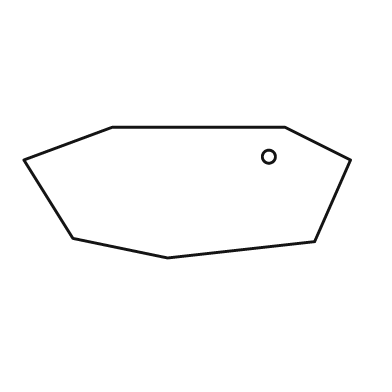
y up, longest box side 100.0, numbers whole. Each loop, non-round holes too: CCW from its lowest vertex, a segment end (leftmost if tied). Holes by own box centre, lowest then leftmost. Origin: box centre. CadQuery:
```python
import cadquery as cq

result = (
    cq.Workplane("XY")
    .moveTo(-6.0, -20.0)
    .lineTo(39.0, -15.0)
    .lineTo(50.0, 10.0)
    .lineTo(30.0, 20.0)
    .lineTo(-23.0, 20.0)
    .lineTo(-50.0, 10.0)
    .lineTo(-35.0, -14.0)
    .close()
    .moveTo(25.0, 11.0)
    .circle(2.0)
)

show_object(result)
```